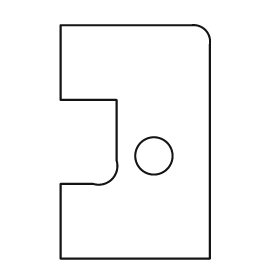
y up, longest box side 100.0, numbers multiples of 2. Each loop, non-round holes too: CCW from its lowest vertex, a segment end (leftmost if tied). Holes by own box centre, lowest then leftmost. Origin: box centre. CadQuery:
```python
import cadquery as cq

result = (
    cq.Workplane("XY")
    .moveTo(-32.0, -50.0)
    .lineTo(32.0, -50.0)
    .lineTo(32.0, 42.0)
    .threePointArc((30.0, 48.0), (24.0, 50.0))
    .lineTo(-32.0, 50.0)
    .lineTo(-32.0, 18.0)
    .lineTo(-8.0, 18.0)
    .lineTo(-8.0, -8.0)
    .threePointArc((-10.0, -16.0), (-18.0, -18.0))
    .lineTo(-32.0, -18.0)
    .close()
    .moveTo(8.0, -6.0)
    .circle(8.0)
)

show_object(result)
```